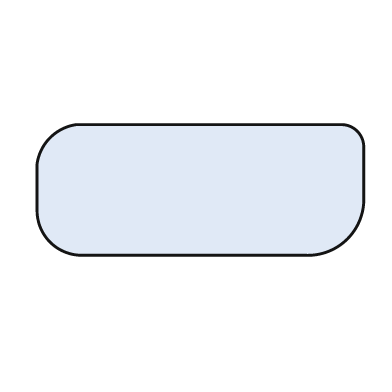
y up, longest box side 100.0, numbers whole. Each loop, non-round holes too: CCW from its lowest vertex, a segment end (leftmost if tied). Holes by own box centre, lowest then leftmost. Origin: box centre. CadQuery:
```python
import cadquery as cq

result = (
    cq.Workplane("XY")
    .moveTo(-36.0, -20.0)
    .lineTo(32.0, -20.0)
    .threePointArc((45.0, -15.0), (50.0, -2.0))
    .lineTo(50.0, 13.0)
    .threePointArc((48.0, 18.0), (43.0, 20.0))
    .lineTo(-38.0, 20.0)
    .threePointArc((-46.0, 16.0), (-50.0, 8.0))
    .lineTo(-50.0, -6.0)
    .threePointArc((-46.0, -16.0), (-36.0, -20.0))
    .close()
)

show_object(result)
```